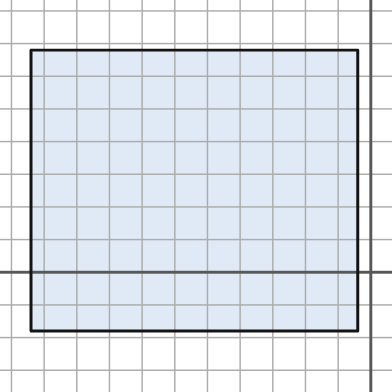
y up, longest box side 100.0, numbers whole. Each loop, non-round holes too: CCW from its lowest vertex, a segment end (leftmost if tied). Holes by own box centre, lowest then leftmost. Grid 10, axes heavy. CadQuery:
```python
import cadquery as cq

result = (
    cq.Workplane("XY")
    .moveTo(-104.0, -18.0)
    .lineTo(-4.0, -18.0)
    .lineTo(-4.0, 68.0)
    .lineTo(-104.0, 68.0)
    .close()
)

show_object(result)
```